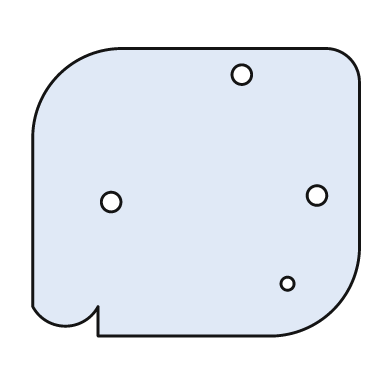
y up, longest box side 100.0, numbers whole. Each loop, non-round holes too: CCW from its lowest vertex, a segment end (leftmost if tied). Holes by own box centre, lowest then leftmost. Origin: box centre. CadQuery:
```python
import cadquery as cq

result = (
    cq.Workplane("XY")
    .moveTo(-30.0, -44.0)
    .lineTo(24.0, -44.0)
    .threePointArc((42.0, -36.0), (50.0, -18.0))
    .lineTo(50.0, 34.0)
    .threePointArc((47.0, 41.0), (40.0, 44.0))
    .lineTo(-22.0, 44.0)
    .threePointArc((-42.0, 36.0), (-50.0, 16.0))
    .lineTo(-50.0, -35.0)
    .threePointArc((-40.0, -41.0), (-30.0, -35.0))
    .close()
    .moveTo(28.0, -28.0)
    .circle(2.0)
    .moveTo(-26.0, -3.0)
    .circle(3.0)
    .moveTo(37.0, -1.0)
    .circle(3.0)
    .moveTo(14.0, 36.0)
    .circle(3.0)
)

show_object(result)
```